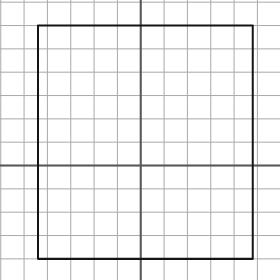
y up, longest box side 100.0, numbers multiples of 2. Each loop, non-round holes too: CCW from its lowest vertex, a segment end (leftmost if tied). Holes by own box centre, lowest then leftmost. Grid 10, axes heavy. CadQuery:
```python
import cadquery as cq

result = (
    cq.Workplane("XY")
    .moveTo(-44.0, -40.0)
    .lineTo(48.0, -40.0)
    .lineTo(48.0, 60.0)
    .lineTo(-44.0, 60.0)
    .close()
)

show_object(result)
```